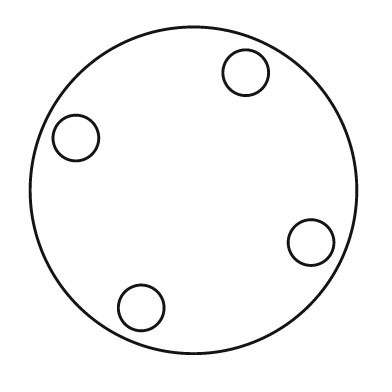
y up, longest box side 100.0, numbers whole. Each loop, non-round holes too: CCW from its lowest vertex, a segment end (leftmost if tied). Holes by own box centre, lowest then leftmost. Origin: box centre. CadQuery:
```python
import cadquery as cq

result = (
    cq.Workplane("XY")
    .moveTo(0.0, 0.0)
    .circle(50.0)
    .moveTo(-16.0, -36.0)
    .circle(7.0)
    .moveTo(36.0, -16.0)
    .circle(7.0)
    .moveTo(-36.0, 16.0)
    .circle(7.0)
    .moveTo(16.0, 36.0)
    .circle(7.0)
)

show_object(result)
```